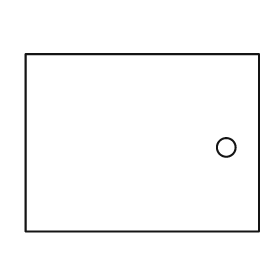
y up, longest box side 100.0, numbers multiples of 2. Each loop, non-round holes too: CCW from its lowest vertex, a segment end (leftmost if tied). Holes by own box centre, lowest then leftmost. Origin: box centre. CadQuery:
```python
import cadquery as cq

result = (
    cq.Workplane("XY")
    .moveTo(-50.0, -38.0)
    .lineTo(50.0, -38.0)
    .lineTo(50.0, 38.0)
    .lineTo(-50.0, 38.0)
    .close()
    .moveTo(36.0, -2.0)
    .circle(4.0)
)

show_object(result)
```